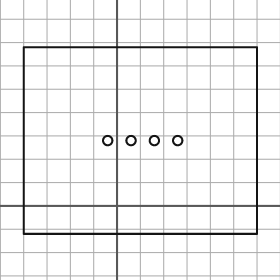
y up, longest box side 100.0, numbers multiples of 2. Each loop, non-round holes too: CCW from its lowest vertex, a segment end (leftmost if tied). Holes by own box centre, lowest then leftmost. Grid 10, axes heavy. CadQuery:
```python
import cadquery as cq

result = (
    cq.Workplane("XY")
    .moveTo(-40.0, -12.0)
    .lineTo(60.0, -12.0)
    .lineTo(60.0, 68.0)
    .lineTo(-40.0, 68.0)
    .close()
    .moveTo(-4.0, 28.0)
    .circle(2.0)
    .moveTo(6.0, 28.0)
    .circle(2.0)
    .moveTo(16.0, 28.0)
    .circle(2.0)
    .moveTo(26.0, 28.0)
    .circle(2.0)
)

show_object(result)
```